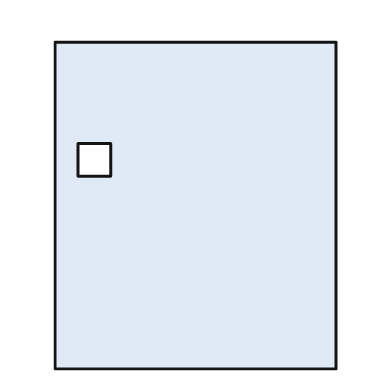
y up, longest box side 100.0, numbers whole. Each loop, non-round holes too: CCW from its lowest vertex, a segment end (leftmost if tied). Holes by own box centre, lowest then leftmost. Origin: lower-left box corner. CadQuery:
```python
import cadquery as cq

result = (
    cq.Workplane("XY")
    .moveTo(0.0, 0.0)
    .lineTo(86.0, 0.0)
    .lineTo(86.0, 100.0)
    .lineTo(0.0, 100.0)
    .close()
    .moveTo(7.0, 59.0)
    .lineTo(17.0, 59.0)
    .lineTo(17.0, 69.0)
    .lineTo(7.0, 69.0)
    .close()
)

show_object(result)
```